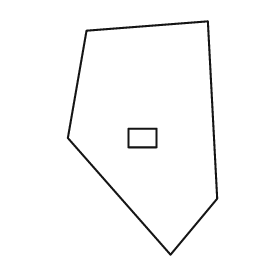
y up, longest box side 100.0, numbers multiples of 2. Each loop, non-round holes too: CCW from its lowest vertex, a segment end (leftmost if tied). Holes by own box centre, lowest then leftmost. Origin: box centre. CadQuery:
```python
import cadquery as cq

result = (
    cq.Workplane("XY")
    .moveTo(12.0, -50.0)
    .lineTo(32.0, -26.0)
    .lineTo(28.0, 50.0)
    .lineTo(-24.0, 46.0)
    .lineTo(-32.0, 0.0)
    .close()
    .moveTo(-6.0, -4.0)
    .lineTo(6.0, -4.0)
    .lineTo(6.0, 4.0)
    .lineTo(-6.0, 4.0)
    .close()
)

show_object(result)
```